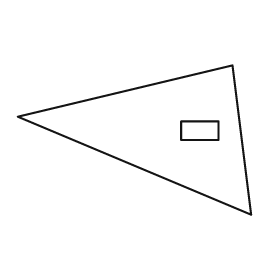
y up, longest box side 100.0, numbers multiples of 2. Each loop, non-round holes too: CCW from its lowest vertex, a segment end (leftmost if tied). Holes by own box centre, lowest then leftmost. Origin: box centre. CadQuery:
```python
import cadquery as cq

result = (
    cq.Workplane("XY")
    .moveTo(50.0, -32.0)
    .lineTo(42.0, 32.0)
    .lineTo(-50.0, 10.0)
    .close()
    .moveTo(20.0, 0.0)
    .lineTo(36.0, 0.0)
    .lineTo(36.0, 8.0)
    .lineTo(20.0, 8.0)
    .close()
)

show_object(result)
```